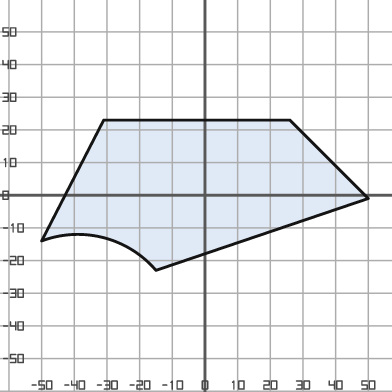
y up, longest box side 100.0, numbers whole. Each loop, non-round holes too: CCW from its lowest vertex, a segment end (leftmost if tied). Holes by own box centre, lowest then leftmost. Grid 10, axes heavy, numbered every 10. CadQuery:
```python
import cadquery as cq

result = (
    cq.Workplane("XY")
    .moveTo(-15.0, -23.0)
    .lineTo(50.0, -1.0)
    .lineTo(26.0, 23.0)
    .lineTo(-31.0, 23.0)
    .lineTo(-50.0, -14.0)
    .threePointArc((-31.0, -13.0), (-15.0, -23.0))
    .close()
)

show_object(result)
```